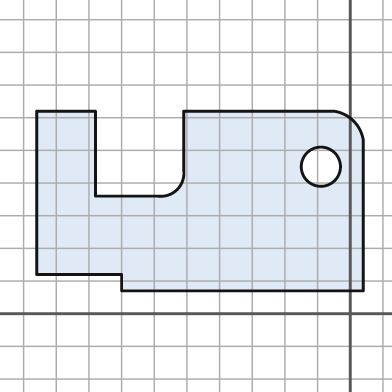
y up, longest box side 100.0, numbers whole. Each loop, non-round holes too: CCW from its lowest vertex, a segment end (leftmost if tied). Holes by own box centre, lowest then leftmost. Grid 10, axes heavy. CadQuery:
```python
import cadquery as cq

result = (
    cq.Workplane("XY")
    .moveTo(-70.0, 7.0)
    .lineTo(4.0, 7.0)
    .lineTo(4.0, 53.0)
    .threePointArc((1.0, 59.0), (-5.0, 62.0))
    .lineTo(-51.0, 62.0)
    .lineTo(-51.0, 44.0)
    .threePointArc((-53.0, 38.0), (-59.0, 36.0))
    .lineTo(-78.0, 36.0)
    .lineTo(-78.0, 62.0)
    .lineTo(-96.0, 62.0)
    .lineTo(-96.0, 12.0)
    .lineTo(-70.0, 12.0)
    .close()
    .moveTo(-9.0, 45.0)
    .circle(6.0)
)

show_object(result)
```